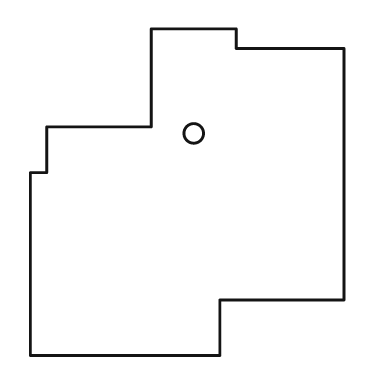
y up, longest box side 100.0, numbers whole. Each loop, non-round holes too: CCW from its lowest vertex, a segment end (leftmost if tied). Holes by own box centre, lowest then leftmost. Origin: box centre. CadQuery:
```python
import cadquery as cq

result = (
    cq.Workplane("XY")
    .moveTo(-48.0, -50.0)
    .lineTo(10.0, -50.0)
    .lineTo(10.0, -33.0)
    .lineTo(48.0, -33.0)
    .lineTo(48.0, 44.0)
    .lineTo(15.0, 44.0)
    .lineTo(15.0, 50.0)
    .lineTo(-11.0, 50.0)
    .lineTo(-11.0, 20.0)
    .lineTo(-43.0, 20.0)
    .lineTo(-43.0, 6.0)
    .lineTo(-48.0, 6.0)
    .close()
    .moveTo(2.0, 18.0)
    .circle(3.0)
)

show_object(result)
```